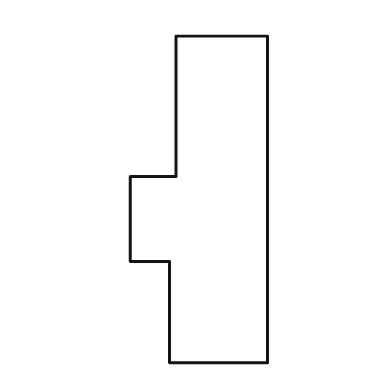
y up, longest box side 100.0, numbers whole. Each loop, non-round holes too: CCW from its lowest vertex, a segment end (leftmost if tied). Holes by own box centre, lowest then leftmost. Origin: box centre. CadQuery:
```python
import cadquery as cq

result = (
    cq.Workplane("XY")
    .moveTo(-9.0, -50.0)
    .lineTo(21.0, -50.0)
    .lineTo(21.0, 50.0)
    .lineTo(-7.0, 50.0)
    .lineTo(-7.0, 7.0)
    .lineTo(-21.0, 7.0)
    .lineTo(-21.0, -19.0)
    .lineTo(-9.0, -19.0)
    .close()
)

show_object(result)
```